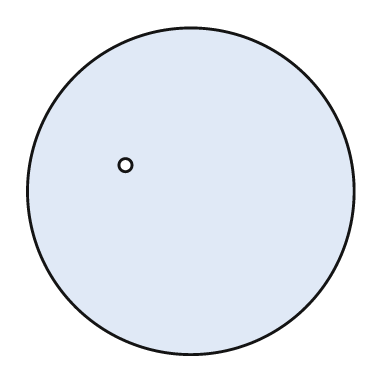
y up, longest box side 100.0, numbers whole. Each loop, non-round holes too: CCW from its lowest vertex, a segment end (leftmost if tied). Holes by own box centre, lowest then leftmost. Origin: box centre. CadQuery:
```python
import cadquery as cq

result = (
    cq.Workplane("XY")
    .moveTo(0.0, 0.0)
    .circle(50.0)
    .moveTo(-20.0, 8.0)
    .circle(2.0)
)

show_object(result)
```